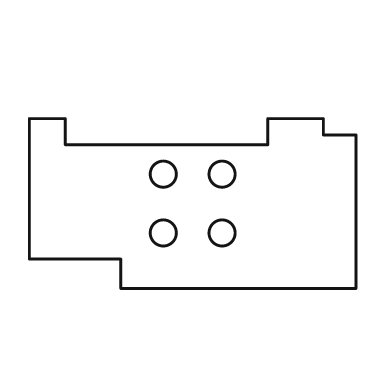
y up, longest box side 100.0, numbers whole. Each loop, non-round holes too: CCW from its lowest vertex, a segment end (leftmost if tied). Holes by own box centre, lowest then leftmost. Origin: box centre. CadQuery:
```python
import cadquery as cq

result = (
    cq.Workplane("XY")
    .moveTo(-22.0, -26.0)
    .lineTo(50.0, -26.0)
    .lineTo(50.0, 21.0)
    .lineTo(40.0, 21.0)
    .lineTo(40.0, 26.0)
    .lineTo(23.0, 26.0)
    .lineTo(23.0, 18.0)
    .lineTo(-39.0, 18.0)
    .lineTo(-39.0, 26.0)
    .lineTo(-50.0, 26.0)
    .lineTo(-50.0, -17.0)
    .lineTo(-22.0, -17.0)
    .close()
    .moveTo(-9.0, -9.0)
    .circle(4.0)
    .moveTo(9.0, -9.0)
    .circle(4.0)
    .moveTo(-9.0, 9.0)
    .circle(4.0)
    .moveTo(9.0, 9.0)
    .circle(4.0)
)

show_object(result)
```